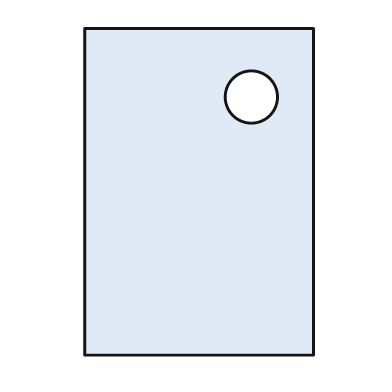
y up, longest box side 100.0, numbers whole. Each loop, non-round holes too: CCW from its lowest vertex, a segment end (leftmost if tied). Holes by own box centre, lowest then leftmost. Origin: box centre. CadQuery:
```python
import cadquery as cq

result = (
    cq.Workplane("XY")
    .moveTo(-35.0, -50.0)
    .lineTo(35.0, -50.0)
    .lineTo(35.0, 50.0)
    .lineTo(-35.0, 50.0)
    .close()
    .moveTo(16.0, 29.0)
    .circle(8.0)
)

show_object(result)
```